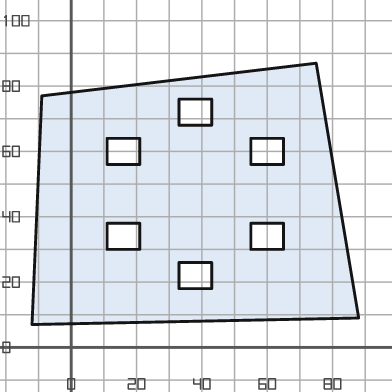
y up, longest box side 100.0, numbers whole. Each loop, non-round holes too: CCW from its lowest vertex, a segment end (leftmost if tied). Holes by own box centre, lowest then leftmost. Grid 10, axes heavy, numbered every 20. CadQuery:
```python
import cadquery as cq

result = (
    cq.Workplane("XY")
    .moveTo(-12.0, 7.0)
    .lineTo(88.0, 9.0)
    .lineTo(75.0, 87.0)
    .lineTo(-9.0, 77.0)
    .close()
    .moveTo(33.0, 18.0)
    .lineTo(43.0, 18.0)
    .lineTo(43.0, 26.0)
    .lineTo(33.0, 26.0)
    .close()
    .moveTo(11.0, 30.0)
    .lineTo(21.0, 30.0)
    .lineTo(21.0, 38.0)
    .lineTo(11.0, 38.0)
    .close()
    .moveTo(55.0, 30.0)
    .lineTo(65.0, 30.0)
    .lineTo(65.0, 38.0)
    .lineTo(55.0, 38.0)
    .close()
    .moveTo(11.0, 56.0)
    .lineTo(21.0, 56.0)
    .lineTo(21.0, 64.0)
    .lineTo(11.0, 64.0)
    .close()
    .moveTo(55.0, 56.0)
    .lineTo(65.0, 56.0)
    .lineTo(65.0, 64.0)
    .lineTo(55.0, 64.0)
    .close()
    .moveTo(33.0, 68.0)
    .lineTo(43.0, 68.0)
    .lineTo(43.0, 76.0)
    .lineTo(33.0, 76.0)
    .close()
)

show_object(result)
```